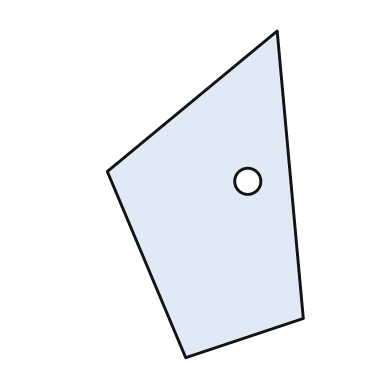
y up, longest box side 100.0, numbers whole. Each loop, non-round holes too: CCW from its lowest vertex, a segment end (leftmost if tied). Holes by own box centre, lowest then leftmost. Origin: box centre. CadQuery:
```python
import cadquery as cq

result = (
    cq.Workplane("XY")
    .moveTo(-6.0, -50.0)
    .lineTo(30.0, -38.0)
    .lineTo(22.0, 50.0)
    .lineTo(-30.0, 7.0)
    .close()
    .moveTo(13.0, 4.0)
    .circle(4.0)
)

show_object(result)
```